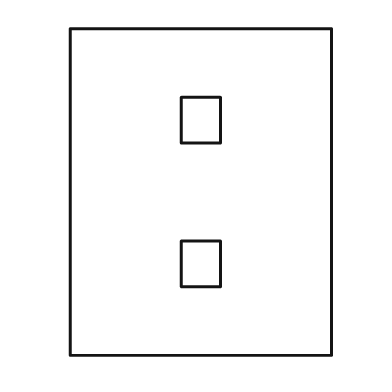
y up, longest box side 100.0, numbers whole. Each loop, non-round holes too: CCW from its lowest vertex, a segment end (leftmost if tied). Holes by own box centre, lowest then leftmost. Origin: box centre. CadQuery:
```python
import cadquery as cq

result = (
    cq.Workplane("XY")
    .moveTo(-40.0, -50.0)
    .lineTo(40.0, -50.0)
    .lineTo(40.0, 50.0)
    .lineTo(-40.0, 50.0)
    .close()
    .moveTo(-6.0, -29.0)
    .lineTo(6.0, -29.0)
    .lineTo(6.0, -15.0)
    .lineTo(-6.0, -15.0)
    .close()
    .moveTo(-6.0, 15.0)
    .lineTo(6.0, 15.0)
    .lineTo(6.0, 29.0)
    .lineTo(-6.0, 29.0)
    .close()
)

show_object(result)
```